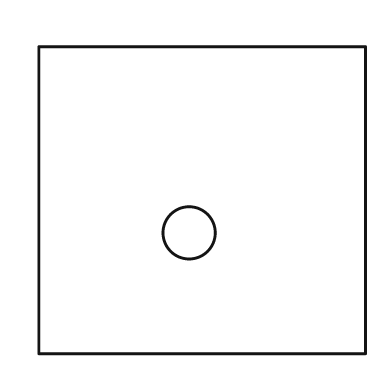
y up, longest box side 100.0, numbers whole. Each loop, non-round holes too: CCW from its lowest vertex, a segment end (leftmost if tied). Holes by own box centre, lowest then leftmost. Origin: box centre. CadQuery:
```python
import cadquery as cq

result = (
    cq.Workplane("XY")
    .moveTo(-50.0, -47.0)
    .lineTo(50.0, -47.0)
    .lineTo(50.0, 47.0)
    .lineTo(-50.0, 47.0)
    .close()
    .moveTo(-4.0, -10.0)
    .circle(8.0)
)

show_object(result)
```